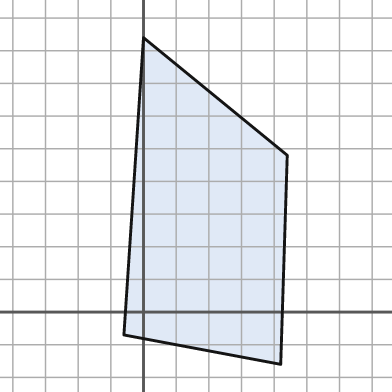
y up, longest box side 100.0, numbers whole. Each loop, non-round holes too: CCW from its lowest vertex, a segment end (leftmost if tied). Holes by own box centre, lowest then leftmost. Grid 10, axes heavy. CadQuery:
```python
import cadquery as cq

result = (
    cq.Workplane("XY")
    .moveTo(42.0, -16.0)
    .lineTo(44.0, 48.0)
    .lineTo(0.0, 84.0)
    .lineTo(-6.0, -7.0)
    .close()
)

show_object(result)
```